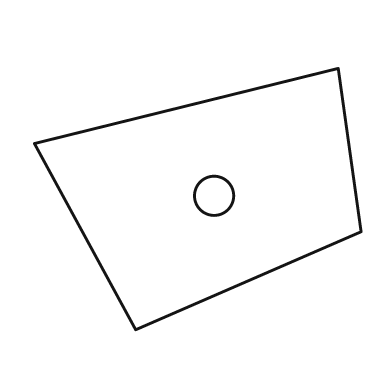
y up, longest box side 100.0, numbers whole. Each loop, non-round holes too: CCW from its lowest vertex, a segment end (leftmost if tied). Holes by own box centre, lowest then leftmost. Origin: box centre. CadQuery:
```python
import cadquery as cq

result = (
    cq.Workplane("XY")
    .moveTo(-19.0, -40.0)
    .lineTo(50.0, -10.0)
    .lineTo(43.0, 40.0)
    .lineTo(-50.0, 17.0)
    .close()
    .moveTo(5.0, 1.0)
    .circle(6.0)
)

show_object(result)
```